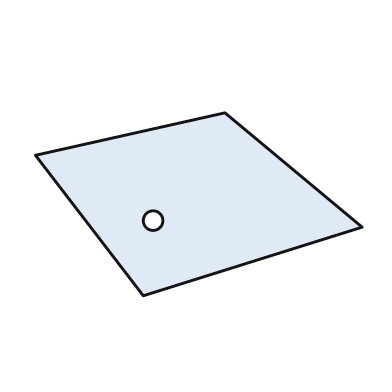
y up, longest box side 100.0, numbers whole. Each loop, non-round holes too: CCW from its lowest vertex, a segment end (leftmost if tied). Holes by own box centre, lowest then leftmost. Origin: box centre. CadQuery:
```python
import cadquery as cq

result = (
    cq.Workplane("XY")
    .moveTo(-17.0, -28.0)
    .lineTo(50.0, -7.0)
    .lineTo(8.0, 28.0)
    .lineTo(-50.0, 15.0)
    .close()
    .moveTo(-14.0, -5.0)
    .circle(3.0)
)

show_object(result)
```